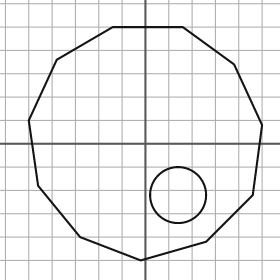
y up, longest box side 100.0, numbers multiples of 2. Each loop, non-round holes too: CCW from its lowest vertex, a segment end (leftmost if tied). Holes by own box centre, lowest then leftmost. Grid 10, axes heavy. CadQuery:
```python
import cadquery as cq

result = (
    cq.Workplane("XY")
    .moveTo(-2.0, -50.0)
    .lineTo(26.0, -42.0)
    .lineTo(46.0, -22.0)
    .lineTo(50.0, 8.0)
    .lineTo(38.0, 34.0)
    .lineTo(16.0, 50.0)
    .lineTo(-14.0, 50.0)
    .lineTo(-38.0, 36.0)
    .lineTo(-50.0, 10.0)
    .lineTo(-46.0, -18.0)
    .lineTo(-28.0, -40.0)
    .close()
    .moveTo(14.0, -22.0)
    .circle(12.0)
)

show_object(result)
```